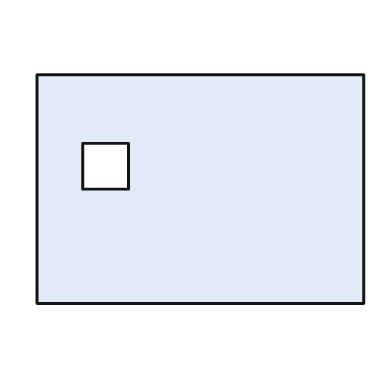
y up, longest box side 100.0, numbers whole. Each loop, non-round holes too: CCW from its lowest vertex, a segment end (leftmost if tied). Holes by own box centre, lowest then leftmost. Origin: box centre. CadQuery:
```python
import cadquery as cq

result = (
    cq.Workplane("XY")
    .moveTo(-50.0, -35.0)
    .lineTo(50.0, -35.0)
    .lineTo(50.0, 35.0)
    .lineTo(-50.0, 35.0)
    .close()
    .moveTo(-36.0, 0.0)
    .lineTo(-22.0, 0.0)
    .lineTo(-22.0, 14.0)
    .lineTo(-36.0, 14.0)
    .close()
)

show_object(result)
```